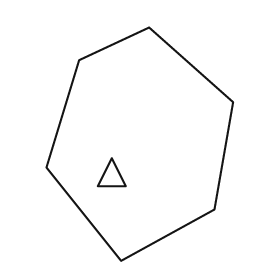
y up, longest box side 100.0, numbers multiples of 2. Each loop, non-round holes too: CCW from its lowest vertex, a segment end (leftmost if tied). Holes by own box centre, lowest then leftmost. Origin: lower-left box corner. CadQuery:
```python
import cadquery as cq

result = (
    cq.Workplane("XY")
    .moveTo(32.0, 0.0)
    .lineTo(72.0, 22.0)
    .lineTo(80.0, 68.0)
    .lineTo(44.0, 100.0)
    .lineTo(14.0, 86.0)
    .lineTo(0.0, 40.0)
    .close()
    .moveTo(22.0, 32.0)
    .lineTo(34.0, 32.0)
    .lineTo(28.0, 44.0)
    .close()
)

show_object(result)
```